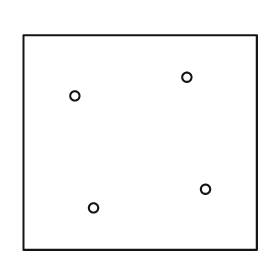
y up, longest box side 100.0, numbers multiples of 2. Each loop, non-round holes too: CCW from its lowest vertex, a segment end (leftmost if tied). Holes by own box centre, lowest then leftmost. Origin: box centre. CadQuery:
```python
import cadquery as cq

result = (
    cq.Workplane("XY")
    .moveTo(-50.0, -46.0)
    .lineTo(50.0, -46.0)
    .lineTo(50.0, 46.0)
    .lineTo(-50.0, 46.0)
    .close()
    .moveTo(-20.0, -28.0)
    .circle(2.0)
    .moveTo(28.0, -20.0)
    .circle(2.0)
    .moveTo(-28.0, 20.0)
    .circle(2.0)
    .moveTo(20.0, 28.0)
    .circle(2.0)
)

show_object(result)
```